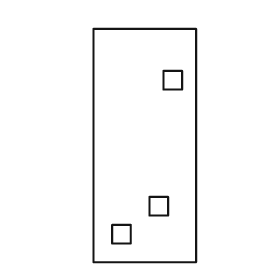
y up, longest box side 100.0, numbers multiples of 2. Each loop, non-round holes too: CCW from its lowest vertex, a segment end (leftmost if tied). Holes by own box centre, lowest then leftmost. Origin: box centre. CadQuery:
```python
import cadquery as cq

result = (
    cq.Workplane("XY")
    .moveTo(-22.0, -50.0)
    .lineTo(22.0, -50.0)
    .lineTo(22.0, 50.0)
    .lineTo(-22.0, 50.0)
    .close()
    .moveTo(-14.0, -42.0)
    .lineTo(-6.0, -42.0)
    .lineTo(-6.0, -34.0)
    .lineTo(-14.0, -34.0)
    .close()
    .moveTo(2.0, -30.0)
    .lineTo(10.0, -30.0)
    .lineTo(10.0, -22.0)
    .lineTo(2.0, -22.0)
    .close()
    .moveTo(8.0, 24.0)
    .lineTo(16.0, 24.0)
    .lineTo(16.0, 32.0)
    .lineTo(8.0, 32.0)
    .close()
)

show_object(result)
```